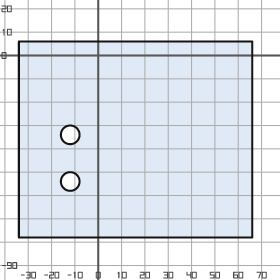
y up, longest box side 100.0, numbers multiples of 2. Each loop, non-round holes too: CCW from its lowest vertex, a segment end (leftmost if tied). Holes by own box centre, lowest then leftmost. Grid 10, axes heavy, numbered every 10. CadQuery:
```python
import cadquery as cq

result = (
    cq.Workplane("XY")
    .moveTo(-34.0, -78.0)
    .lineTo(66.0, -78.0)
    .lineTo(66.0, 6.0)
    .lineTo(-34.0, 6.0)
    .close()
    .moveTo(-12.0, -54.0)
    .circle(4.0)
    .moveTo(-12.0, -34.0)
    .circle(4.0)
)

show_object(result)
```